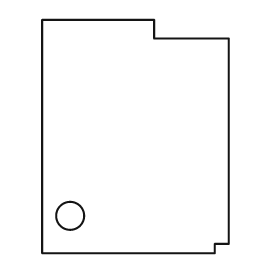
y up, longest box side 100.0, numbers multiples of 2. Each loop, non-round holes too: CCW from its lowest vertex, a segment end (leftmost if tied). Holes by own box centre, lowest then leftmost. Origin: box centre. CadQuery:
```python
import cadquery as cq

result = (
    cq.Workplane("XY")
    .moveTo(-40.0, -50.0)
    .lineTo(34.0, -50.0)
    .lineTo(34.0, -46.0)
    .lineTo(40.0, -46.0)
    .lineTo(40.0, 42.0)
    .lineTo(8.0, 42.0)
    .lineTo(8.0, 50.0)
    .lineTo(-40.0, 50.0)
    .close()
    .moveTo(-28.0, -34.0)
    .circle(6.0)
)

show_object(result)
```